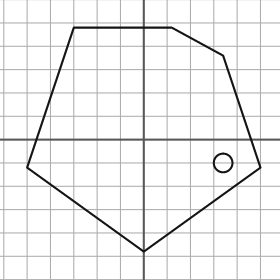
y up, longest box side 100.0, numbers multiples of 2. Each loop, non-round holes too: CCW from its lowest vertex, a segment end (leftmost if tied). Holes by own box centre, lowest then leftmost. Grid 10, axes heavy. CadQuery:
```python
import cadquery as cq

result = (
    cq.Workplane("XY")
    .moveTo(0.0, -48.0)
    .lineTo(50.0, -12.0)
    .lineTo(34.0, 36.0)
    .lineTo(12.0, 48.0)
    .lineTo(-30.0, 48.0)
    .lineTo(-50.0, -12.0)
    .close()
    .moveTo(34.0, -10.0)
    .circle(4.0)
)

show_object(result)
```